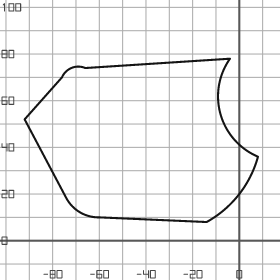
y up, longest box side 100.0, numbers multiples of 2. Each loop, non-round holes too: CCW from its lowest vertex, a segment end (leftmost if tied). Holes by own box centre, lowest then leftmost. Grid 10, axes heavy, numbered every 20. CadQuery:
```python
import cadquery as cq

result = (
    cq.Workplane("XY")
    .moveTo(-14.0, 8.0)
    .threePointArc((0.0, 20.0), (8.0, 36.0))
    .threePointArc((-8.0, 54.0), (-4.0, 78.0))
    .lineTo(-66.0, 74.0)
    .threePointArc((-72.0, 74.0), (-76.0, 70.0))
    .lineTo(-92.0, 52.0)
    .lineTo(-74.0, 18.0)
    .threePointArc((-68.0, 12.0), (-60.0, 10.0))
    .close()
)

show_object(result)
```